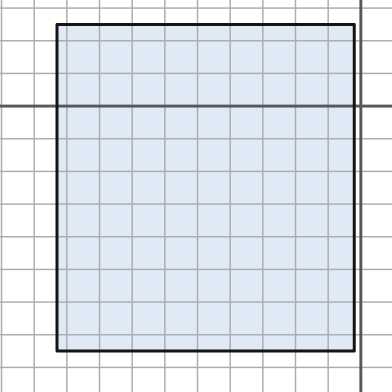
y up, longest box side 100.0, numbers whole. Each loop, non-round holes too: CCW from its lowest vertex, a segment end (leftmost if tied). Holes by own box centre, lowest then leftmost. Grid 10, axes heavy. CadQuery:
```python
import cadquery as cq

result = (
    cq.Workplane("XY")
    .moveTo(-93.0, -75.0)
    .lineTo(-2.0, -75.0)
    .lineTo(-2.0, 25.0)
    .lineTo(-93.0, 25.0)
    .close()
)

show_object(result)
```